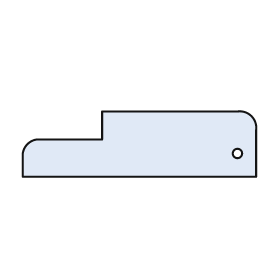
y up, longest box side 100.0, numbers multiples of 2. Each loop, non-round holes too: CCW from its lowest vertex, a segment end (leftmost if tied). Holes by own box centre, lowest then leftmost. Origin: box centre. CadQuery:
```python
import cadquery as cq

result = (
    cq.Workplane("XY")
    .moveTo(-50.0, -14.0)
    .lineTo(50.0, -14.0)
    .lineTo(50.0, 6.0)
    .threePointArc((48.0, 12.0), (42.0, 14.0))
    .lineTo(-16.0, 14.0)
    .lineTo(-16.0, 2.0)
    .lineTo(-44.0, 2.0)
    .threePointArc((-48.0, 0.0), (-50.0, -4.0))
    .close()
    .moveTo(42.0, -4.0)
    .circle(2.0)
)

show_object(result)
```